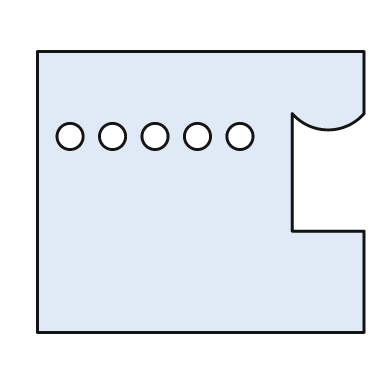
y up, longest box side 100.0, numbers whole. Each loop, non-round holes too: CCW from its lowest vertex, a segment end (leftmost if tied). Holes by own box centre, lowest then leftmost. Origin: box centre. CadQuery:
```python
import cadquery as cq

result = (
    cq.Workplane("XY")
    .moveTo(-50.0, -43.0)
    .lineTo(50.0, -43.0)
    .lineTo(50.0, -12.0)
    .lineTo(28.0, -12.0)
    .lineTo(28.0, 24.0)
    .threePointArc((39.0, 19.0), (50.0, 24.0))
    .lineTo(50.0, 43.0)
    .lineTo(-50.0, 43.0)
    .close()
    .moveTo(-40.0, 17.0)
    .circle(4.0)
    .moveTo(-27.0, 17.0)
    .circle(4.0)
    .moveTo(-14.0, 17.0)
    .circle(4.0)
    .moveTo(-1.0, 17.0)
    .circle(4.0)
    .moveTo(12.0, 17.0)
    .circle(4.0)
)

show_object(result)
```